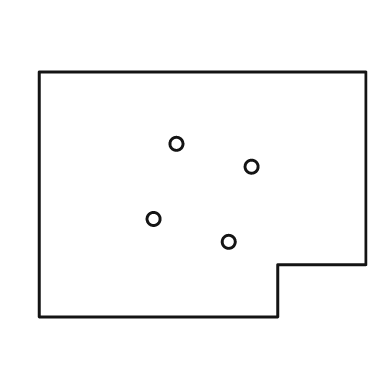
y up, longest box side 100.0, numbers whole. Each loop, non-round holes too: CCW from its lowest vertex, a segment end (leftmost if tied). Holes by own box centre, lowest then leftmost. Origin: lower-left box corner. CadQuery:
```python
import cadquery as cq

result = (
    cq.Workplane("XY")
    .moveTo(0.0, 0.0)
    .lineTo(73.0, 0.0)
    .lineTo(73.0, 16.0)
    .lineTo(100.0, 16.0)
    .lineTo(100.0, 75.0)
    .lineTo(0.0, 75.0)
    .close()
    .moveTo(58.0, 23.0)
    .circle(2.0)
    .moveTo(35.0, 30.0)
    .circle(2.0)
    .moveTo(65.0, 46.0)
    .circle(2.0)
    .moveTo(42.0, 53.0)
    .circle(2.0)
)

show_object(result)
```